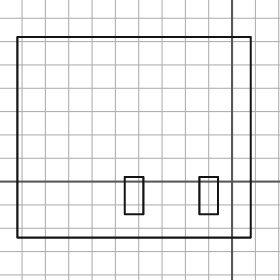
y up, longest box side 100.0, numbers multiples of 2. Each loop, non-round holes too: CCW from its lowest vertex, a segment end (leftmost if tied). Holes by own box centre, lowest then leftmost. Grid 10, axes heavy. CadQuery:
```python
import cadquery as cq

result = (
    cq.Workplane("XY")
    .moveTo(-92.0, -24.0)
    .lineTo(8.0, -24.0)
    .lineTo(8.0, 62.0)
    .lineTo(-92.0, 62.0)
    .close()
    .moveTo(-46.0, -14.0)
    .lineTo(-38.0, -14.0)
    .lineTo(-38.0, 2.0)
    .lineTo(-46.0, 2.0)
    .close()
    .moveTo(-14.0, -14.0)
    .lineTo(-6.0, -14.0)
    .lineTo(-6.0, 2.0)
    .lineTo(-14.0, 2.0)
    .close()
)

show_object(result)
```